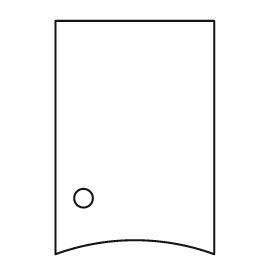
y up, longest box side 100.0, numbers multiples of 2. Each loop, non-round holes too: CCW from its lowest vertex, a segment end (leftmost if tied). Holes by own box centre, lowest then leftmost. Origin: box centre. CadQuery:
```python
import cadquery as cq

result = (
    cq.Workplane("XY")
    .moveTo(-34.0, -50.0)
    .threePointArc((0.0, -44.0), (34.0, -50.0))
    .lineTo(34.0, 50.0)
    .lineTo(-34.0, 50.0)
    .close()
    .moveTo(-22.0, -26.0)
    .circle(4.0)
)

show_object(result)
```